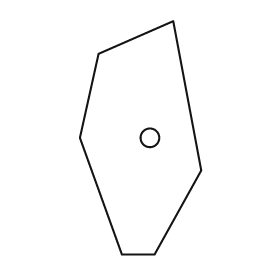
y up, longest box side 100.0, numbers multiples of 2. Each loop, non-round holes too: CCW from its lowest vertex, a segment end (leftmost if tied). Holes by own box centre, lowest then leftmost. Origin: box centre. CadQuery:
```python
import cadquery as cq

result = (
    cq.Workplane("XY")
    .moveTo(-8.0, -50.0)
    .lineTo(6.0, -50.0)
    .lineTo(26.0, -14.0)
    .lineTo(14.0, 50.0)
    .lineTo(-18.0, 36.0)
    .lineTo(-26.0, 0.0)
    .close()
    .moveTo(4.0, 0.0)
    .circle(4.0)
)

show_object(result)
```